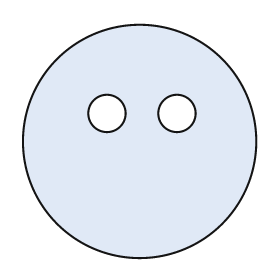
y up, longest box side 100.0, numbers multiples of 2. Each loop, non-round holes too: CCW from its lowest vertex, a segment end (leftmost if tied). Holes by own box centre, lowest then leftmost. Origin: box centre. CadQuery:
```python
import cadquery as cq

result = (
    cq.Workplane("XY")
    .moveTo(0.0, 0.0)
    .circle(50.0)
    .moveTo(-14.0, 12.0)
    .circle(8.0)
    .moveTo(16.0, 12.0)
    .circle(8.0)
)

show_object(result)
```